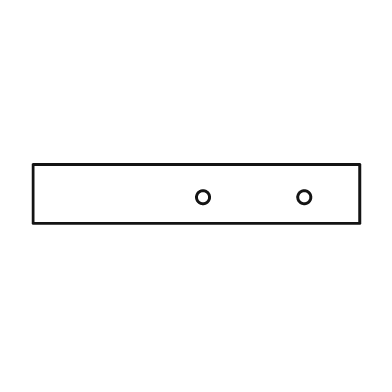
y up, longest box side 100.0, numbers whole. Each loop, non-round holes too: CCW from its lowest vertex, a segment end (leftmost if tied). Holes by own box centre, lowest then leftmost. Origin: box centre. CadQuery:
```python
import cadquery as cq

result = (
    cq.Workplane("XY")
    .moveTo(-50.0, -9.0)
    .lineTo(50.0, -9.0)
    .lineTo(50.0, 9.0)
    .lineTo(-50.0, 9.0)
    .close()
    .moveTo(2.0, -1.0)
    .circle(2.0)
    .moveTo(33.0, -1.0)
    .circle(2.0)
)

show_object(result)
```